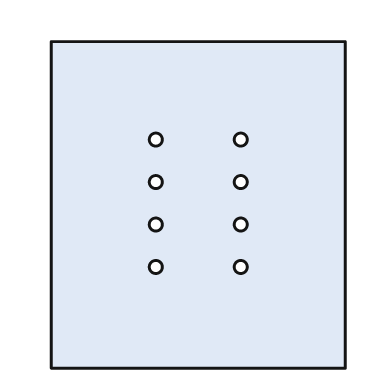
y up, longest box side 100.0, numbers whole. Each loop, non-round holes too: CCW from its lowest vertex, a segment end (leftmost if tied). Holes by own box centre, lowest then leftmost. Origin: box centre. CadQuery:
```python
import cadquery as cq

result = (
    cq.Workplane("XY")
    .moveTo(-45.0, -50.0)
    .lineTo(45.0, -50.0)
    .lineTo(45.0, 50.0)
    .lineTo(-45.0, 50.0)
    .close()
    .moveTo(-13.0, -19.0)
    .circle(2.0)
    .moveTo(13.0, -19.0)
    .circle(2.0)
    .moveTo(-13.0, -6.0)
    .circle(2.0)
    .moveTo(13.0, -6.0)
    .circle(2.0)
    .moveTo(-13.0, 7.0)
    .circle(2.0)
    .moveTo(13.0, 7.0)
    .circle(2.0)
    .moveTo(-13.0, 20.0)
    .circle(2.0)
    .moveTo(13.0, 20.0)
    .circle(2.0)
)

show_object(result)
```